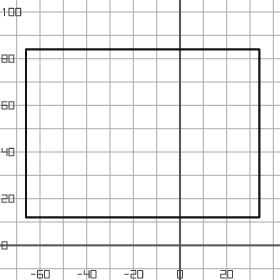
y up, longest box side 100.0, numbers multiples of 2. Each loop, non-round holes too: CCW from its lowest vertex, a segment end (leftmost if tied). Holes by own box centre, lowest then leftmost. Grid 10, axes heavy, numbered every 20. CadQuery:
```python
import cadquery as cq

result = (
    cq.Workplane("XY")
    .moveTo(-66.0, 12.0)
    .lineTo(34.0, 12.0)
    .lineTo(34.0, 84.0)
    .lineTo(-66.0, 84.0)
    .close()
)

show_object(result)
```